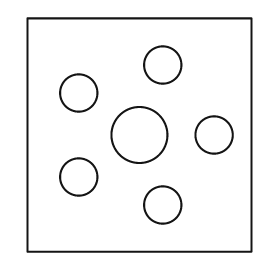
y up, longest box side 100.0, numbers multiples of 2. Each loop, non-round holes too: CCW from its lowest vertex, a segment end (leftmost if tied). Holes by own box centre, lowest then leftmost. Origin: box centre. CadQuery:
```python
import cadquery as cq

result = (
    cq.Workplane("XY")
    .moveTo(-48.0, -50.0)
    .lineTo(48.0, -50.0)
    .lineTo(48.0, 50.0)
    .lineTo(-48.0, 50.0)
    .close()
    .moveTo(10.0, -30.0)
    .circle(8.0)
    .moveTo(-26.0, -18.0)
    .circle(8.0)
    .moveTo(0.0, 0.0)
    .circle(12.0)
    .moveTo(32.0, 0.0)
    .circle(8.0)
    .moveTo(-26.0, 18.0)
    .circle(8.0)
    .moveTo(10.0, 30.0)
    .circle(8.0)
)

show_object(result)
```